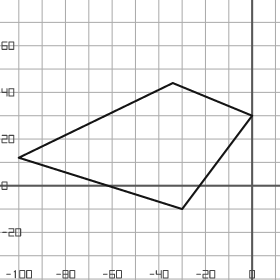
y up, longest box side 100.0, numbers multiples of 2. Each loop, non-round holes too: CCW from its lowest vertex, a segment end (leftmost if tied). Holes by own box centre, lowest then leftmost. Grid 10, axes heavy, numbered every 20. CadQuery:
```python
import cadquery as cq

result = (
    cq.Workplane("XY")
    .moveTo(-30.0, -10.0)
    .lineTo(0.0, 30.0)
    .lineTo(-34.0, 44.0)
    .lineTo(-100.0, 12.0)
    .close()
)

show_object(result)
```